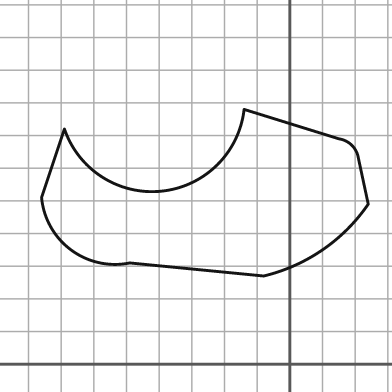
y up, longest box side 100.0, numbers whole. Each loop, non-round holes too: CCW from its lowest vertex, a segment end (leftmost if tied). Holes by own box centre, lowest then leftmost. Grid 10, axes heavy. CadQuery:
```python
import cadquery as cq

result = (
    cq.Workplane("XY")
    .moveTo(-8.0, 27.0)
    .threePointArc((10.0, 35.0), (24.0, 49.0))
    .lineTo(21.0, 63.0)
    .threePointArc((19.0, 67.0), (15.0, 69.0))
    .lineTo(-14.0, 78.0)
    .threePointArc((-39.0, 53.0), (-69.0, 72.0))
    .lineTo(-76.0, 51.0)
    .threePointArc((-67.0, 35.0), (-49.0, 31.0))
    .close()
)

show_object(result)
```